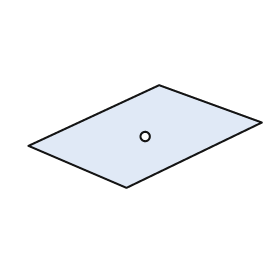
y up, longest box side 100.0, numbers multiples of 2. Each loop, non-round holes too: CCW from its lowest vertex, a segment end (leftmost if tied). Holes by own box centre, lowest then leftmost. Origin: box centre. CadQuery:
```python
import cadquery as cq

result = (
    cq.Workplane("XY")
    .moveTo(-8.0, -22.0)
    .lineTo(50.0, 6.0)
    .lineTo(6.0, 22.0)
    .lineTo(-50.0, -4.0)
    .close()
    .moveTo(0.0, 0.0)
    .circle(2.0)
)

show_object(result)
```